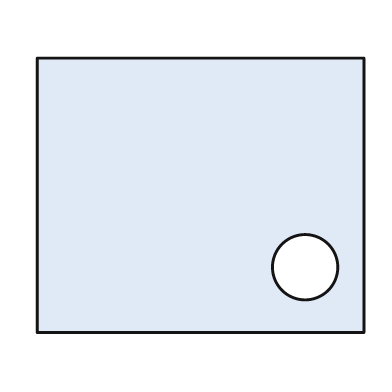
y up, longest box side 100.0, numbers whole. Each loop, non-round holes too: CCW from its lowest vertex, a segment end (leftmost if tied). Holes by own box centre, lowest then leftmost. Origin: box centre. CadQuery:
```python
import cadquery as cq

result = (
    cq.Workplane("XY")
    .moveTo(-50.0, -42.0)
    .lineTo(50.0, -42.0)
    .lineTo(50.0, 42.0)
    .lineTo(-50.0, 42.0)
    .close()
    .moveTo(32.0, -22.0)
    .circle(10.0)
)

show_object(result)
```